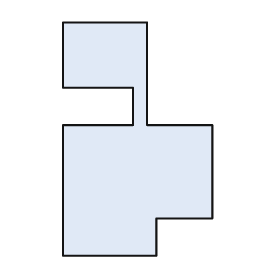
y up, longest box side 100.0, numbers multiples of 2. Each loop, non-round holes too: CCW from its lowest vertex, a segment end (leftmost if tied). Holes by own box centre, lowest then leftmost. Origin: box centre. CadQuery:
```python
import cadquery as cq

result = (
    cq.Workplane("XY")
    .moveTo(-32.0, -50.0)
    .lineTo(8.0, -50.0)
    .lineTo(8.0, -34.0)
    .lineTo(32.0, -34.0)
    .lineTo(32.0, 6.0)
    .lineTo(4.0, 6.0)
    .lineTo(4.0, 50.0)
    .lineTo(-32.0, 50.0)
    .lineTo(-32.0, 22.0)
    .lineTo(-2.0, 22.0)
    .lineTo(-2.0, 6.0)
    .lineTo(-32.0, 6.0)
    .close()
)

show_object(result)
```